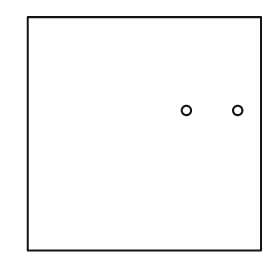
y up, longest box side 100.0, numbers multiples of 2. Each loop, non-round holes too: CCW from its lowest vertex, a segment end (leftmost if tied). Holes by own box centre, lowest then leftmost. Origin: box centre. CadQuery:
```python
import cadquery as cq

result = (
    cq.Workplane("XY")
    .moveTo(-50.0, -50.0)
    .lineTo(50.0, -50.0)
    .lineTo(50.0, 50.0)
    .lineTo(-50.0, 50.0)
    .close()
    .moveTo(18.0, 10.0)
    .circle(2.0)
    .moveTo(40.0, 10.0)
    .circle(2.0)
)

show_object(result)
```